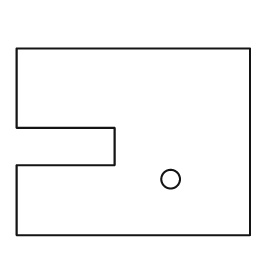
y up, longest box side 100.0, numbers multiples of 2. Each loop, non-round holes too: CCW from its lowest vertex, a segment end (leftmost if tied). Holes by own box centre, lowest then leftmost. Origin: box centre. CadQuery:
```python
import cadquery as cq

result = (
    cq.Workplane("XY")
    .moveTo(-50.0, -40.0)
    .lineTo(50.0, -40.0)
    .lineTo(50.0, 40.0)
    .lineTo(-50.0, 40.0)
    .lineTo(-50.0, 6.0)
    .lineTo(-8.0, 6.0)
    .lineTo(-8.0, -10.0)
    .lineTo(-50.0, -10.0)
    .close()
    .moveTo(16.0, -16.0)
    .circle(4.0)
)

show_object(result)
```